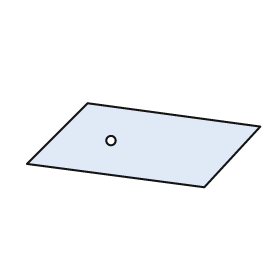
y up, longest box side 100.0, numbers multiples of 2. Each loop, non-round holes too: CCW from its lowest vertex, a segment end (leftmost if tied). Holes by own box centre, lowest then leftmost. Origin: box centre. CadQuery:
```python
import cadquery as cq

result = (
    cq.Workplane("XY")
    .moveTo(26.0, -18.0)
    .lineTo(50.0, 8.0)
    .lineTo(-24.0, 18.0)
    .lineTo(-50.0, -8.0)
    .close()
    .moveTo(-14.0, 2.0)
    .circle(2.0)
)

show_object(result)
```